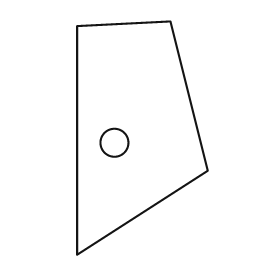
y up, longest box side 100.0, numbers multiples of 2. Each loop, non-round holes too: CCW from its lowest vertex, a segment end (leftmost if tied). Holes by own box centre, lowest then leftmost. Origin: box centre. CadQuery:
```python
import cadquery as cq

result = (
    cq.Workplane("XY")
    .moveTo(-28.0, -50.0)
    .lineTo(28.0, -14.0)
    .lineTo(12.0, 50.0)
    .lineTo(-28.0, 48.0)
    .close()
    .moveTo(-12.0, -2.0)
    .circle(6.0)
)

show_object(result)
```